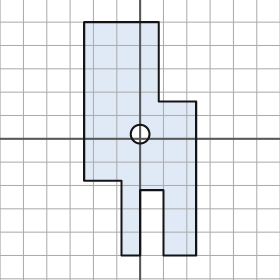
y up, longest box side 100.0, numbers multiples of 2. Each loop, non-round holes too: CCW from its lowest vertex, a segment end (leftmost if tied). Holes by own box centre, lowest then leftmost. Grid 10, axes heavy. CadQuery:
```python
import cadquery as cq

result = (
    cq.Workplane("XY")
    .moveTo(-8.0, -50.0)
    .lineTo(0.0, -50.0)
    .lineTo(0.0, -22.0)
    .lineTo(10.0, -22.0)
    .lineTo(10.0, -50.0)
    .lineTo(24.0, -50.0)
    .lineTo(24.0, 16.0)
    .lineTo(8.0, 16.0)
    .lineTo(8.0, 50.0)
    .lineTo(-24.0, 50.0)
    .lineTo(-24.0, -18.0)
    .lineTo(-8.0, -18.0)
    .close()
    .moveTo(0.0, 2.0)
    .circle(4.0)
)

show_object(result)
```